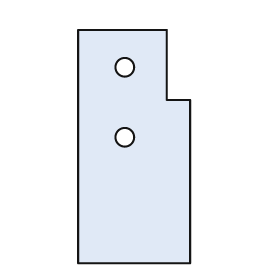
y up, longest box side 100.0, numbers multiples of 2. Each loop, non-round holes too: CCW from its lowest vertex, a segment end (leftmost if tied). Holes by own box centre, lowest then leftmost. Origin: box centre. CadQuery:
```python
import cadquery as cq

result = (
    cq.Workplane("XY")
    .moveTo(-24.0, -50.0)
    .lineTo(24.0, -50.0)
    .lineTo(24.0, 20.0)
    .lineTo(14.0, 20.0)
    .lineTo(14.0, 50.0)
    .lineTo(-24.0, 50.0)
    .close()
    .moveTo(-4.0, 4.0)
    .circle(4.0)
    .moveTo(-4.0, 34.0)
    .circle(4.0)
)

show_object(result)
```